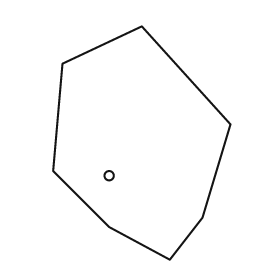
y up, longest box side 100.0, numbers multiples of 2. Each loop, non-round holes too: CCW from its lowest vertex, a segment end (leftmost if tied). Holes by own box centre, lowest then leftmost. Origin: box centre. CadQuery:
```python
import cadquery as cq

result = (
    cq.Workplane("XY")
    .moveTo(12.0, -50.0)
    .lineTo(26.0, -32.0)
    .lineTo(38.0, 8.0)
    .lineTo(0.0, 50.0)
    .lineTo(-34.0, 34.0)
    .lineTo(-38.0, -12.0)
    .lineTo(-14.0, -36.0)
    .close()
    .moveTo(-14.0, -14.0)
    .circle(2.0)
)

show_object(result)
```